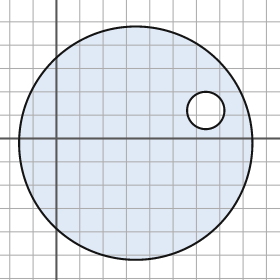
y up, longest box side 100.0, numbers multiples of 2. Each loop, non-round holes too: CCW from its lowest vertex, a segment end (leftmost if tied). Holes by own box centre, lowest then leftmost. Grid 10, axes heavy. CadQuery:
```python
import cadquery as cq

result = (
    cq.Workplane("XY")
    .moveTo(34.0, -2.0)
    .circle(50.0)
    .moveTo(64.0, 12.0)
    .circle(8.0)
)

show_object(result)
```